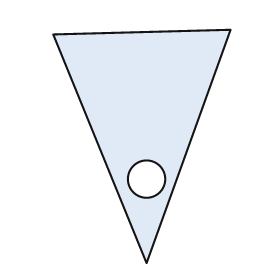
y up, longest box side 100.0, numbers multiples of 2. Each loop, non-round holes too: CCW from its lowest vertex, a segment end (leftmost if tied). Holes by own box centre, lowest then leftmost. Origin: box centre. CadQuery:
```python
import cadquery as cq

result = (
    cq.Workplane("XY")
    .moveTo(2.0, -50.0)
    .lineTo(38.0, 50.0)
    .lineTo(-38.0, 48.0)
    .close()
    .moveTo(2.0, -14.0)
    .circle(8.0)
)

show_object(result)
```